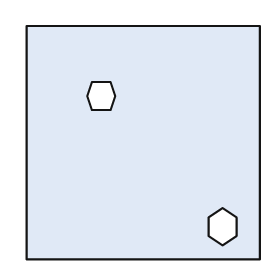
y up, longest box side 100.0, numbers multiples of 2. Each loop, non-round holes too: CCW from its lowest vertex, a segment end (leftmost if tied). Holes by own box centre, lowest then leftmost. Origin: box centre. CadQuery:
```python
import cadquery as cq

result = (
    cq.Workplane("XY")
    .moveTo(-50.0, -50.0)
    .lineTo(50.0, -50.0)
    .lineTo(50.0, 50.0)
    .lineTo(-50.0, 50.0)
    .close()
    .moveTo(34.0, -44.0)
    .lineTo(40.0, -40.0)
    .lineTo(40.0, -32.0)
    .lineTo(34.0, -28.0)
    .lineTo(28.0, -32.0)
    .lineTo(28.0, -40.0)
    .close()
    .moveTo(-22.0, 14.0)
    .lineTo(-14.0, 14.0)
    .lineTo(-12.0, 20.0)
    .lineTo(-14.0, 26.0)
    .lineTo(-22.0, 26.0)
    .lineTo(-24.0, 20.0)
    .close()
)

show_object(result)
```